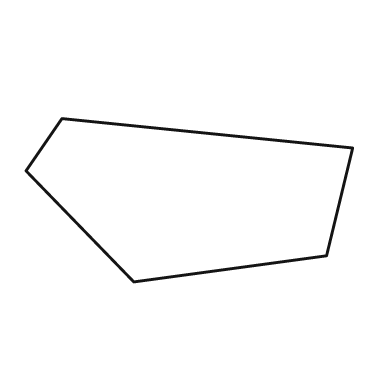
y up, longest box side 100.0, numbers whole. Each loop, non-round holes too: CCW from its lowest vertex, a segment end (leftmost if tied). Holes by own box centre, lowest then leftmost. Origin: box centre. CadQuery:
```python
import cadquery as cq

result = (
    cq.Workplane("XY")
    .moveTo(-17.0, -25.0)
    .lineTo(42.0, -17.0)
    .lineTo(50.0, 16.0)
    .lineTo(-39.0, 25.0)
    .lineTo(-50.0, 9.0)
    .close()
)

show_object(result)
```